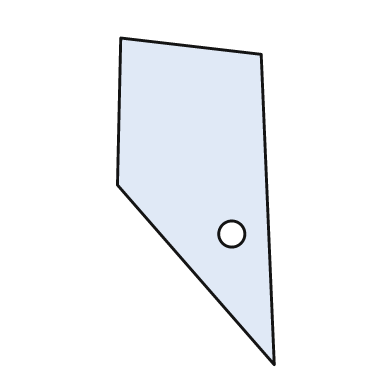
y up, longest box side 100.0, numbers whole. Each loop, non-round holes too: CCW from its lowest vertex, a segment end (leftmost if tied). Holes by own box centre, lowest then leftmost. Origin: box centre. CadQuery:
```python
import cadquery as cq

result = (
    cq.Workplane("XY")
    .moveTo(24.0, -50.0)
    .lineTo(20.0, 45.0)
    .lineTo(-23.0, 50.0)
    .lineTo(-24.0, 5.0)
    .close()
    .moveTo(11.0, -10.0)
    .circle(4.0)
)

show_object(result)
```